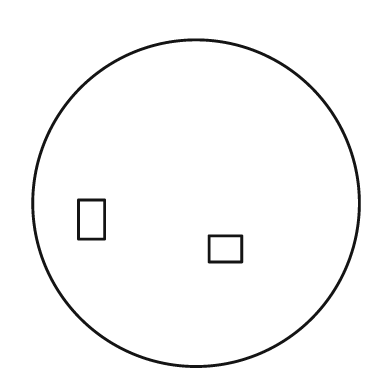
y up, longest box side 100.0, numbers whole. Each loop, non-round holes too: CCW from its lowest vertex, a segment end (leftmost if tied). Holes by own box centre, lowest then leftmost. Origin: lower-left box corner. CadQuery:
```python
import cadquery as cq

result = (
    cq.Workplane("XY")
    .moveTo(50.0, 50.0)
    .circle(50.0)
    .moveTo(54.0, 32.0)
    .lineTo(64.0, 32.0)
    .lineTo(64.0, 40.0)
    .lineTo(54.0, 40.0)
    .close()
    .moveTo(14.0, 39.0)
    .lineTo(22.0, 39.0)
    .lineTo(22.0, 51.0)
    .lineTo(14.0, 51.0)
    .close()
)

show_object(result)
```